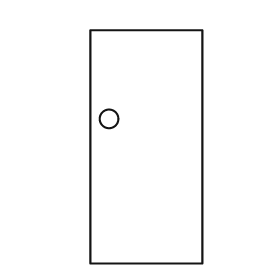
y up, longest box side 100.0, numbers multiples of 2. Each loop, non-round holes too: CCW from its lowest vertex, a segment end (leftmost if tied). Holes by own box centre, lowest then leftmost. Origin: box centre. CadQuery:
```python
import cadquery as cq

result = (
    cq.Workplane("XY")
    .moveTo(-24.0, -50.0)
    .lineTo(24.0, -50.0)
    .lineTo(24.0, 50.0)
    .lineTo(-24.0, 50.0)
    .close()
    .moveTo(-16.0, 12.0)
    .circle(4.0)
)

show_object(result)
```